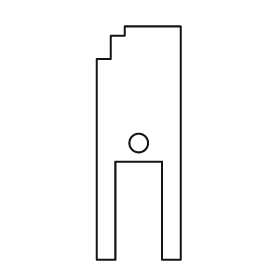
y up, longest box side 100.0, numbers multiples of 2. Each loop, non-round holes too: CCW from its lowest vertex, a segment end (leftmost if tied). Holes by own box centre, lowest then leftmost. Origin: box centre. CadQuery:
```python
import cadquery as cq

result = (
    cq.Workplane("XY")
    .moveTo(-18.0, -50.0)
    .lineTo(-10.0, -50.0)
    .lineTo(-10.0, -8.0)
    .lineTo(10.0, -8.0)
    .lineTo(10.0, -50.0)
    .lineTo(18.0, -50.0)
    .lineTo(18.0, 50.0)
    .lineTo(-6.0, 50.0)
    .lineTo(-6.0, 46.0)
    .lineTo(-12.0, 46.0)
    .lineTo(-12.0, 36.0)
    .lineTo(-18.0, 36.0)
    .close()
    .moveTo(0.0, 0.0)
    .circle(4.0)
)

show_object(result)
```